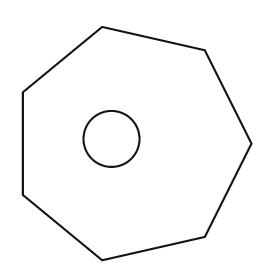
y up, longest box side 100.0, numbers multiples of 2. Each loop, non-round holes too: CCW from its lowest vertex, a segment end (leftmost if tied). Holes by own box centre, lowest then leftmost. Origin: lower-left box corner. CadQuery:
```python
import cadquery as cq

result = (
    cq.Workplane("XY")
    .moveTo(34.0, 0.0)
    .lineTo(78.0, 10.0)
    .lineTo(98.0, 50.0)
    .lineTo(78.0, 90.0)
    .lineTo(34.0, 100.0)
    .lineTo(0.0, 72.0)
    .lineTo(0.0, 28.0)
    .close()
    .moveTo(38.0, 52.0)
    .circle(12.0)
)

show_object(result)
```